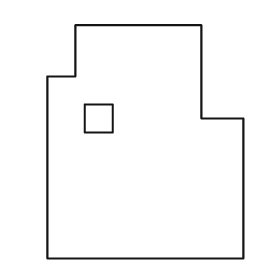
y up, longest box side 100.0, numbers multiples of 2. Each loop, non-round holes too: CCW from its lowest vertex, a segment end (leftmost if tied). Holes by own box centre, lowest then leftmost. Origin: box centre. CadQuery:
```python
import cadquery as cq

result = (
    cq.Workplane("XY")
    .moveTo(-42.0, -50.0)
    .lineTo(42.0, -50.0)
    .lineTo(42.0, 10.0)
    .lineTo(24.0, 10.0)
    .lineTo(24.0, 50.0)
    .lineTo(-30.0, 50.0)
    .lineTo(-30.0, 28.0)
    .lineTo(-42.0, 28.0)
    .close()
    .moveTo(-26.0, 4.0)
    .lineTo(-14.0, 4.0)
    .lineTo(-14.0, 16.0)
    .lineTo(-26.0, 16.0)
    .close()
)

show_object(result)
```